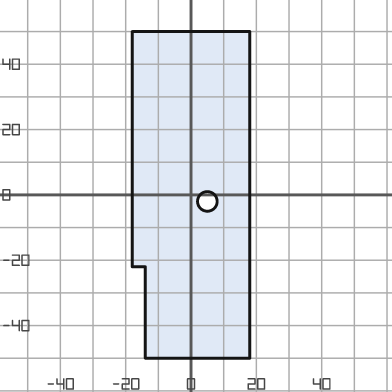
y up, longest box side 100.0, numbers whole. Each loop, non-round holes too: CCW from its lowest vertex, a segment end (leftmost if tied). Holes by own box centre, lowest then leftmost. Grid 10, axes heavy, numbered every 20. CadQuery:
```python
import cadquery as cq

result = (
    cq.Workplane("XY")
    .moveTo(-14.0, -50.0)
    .lineTo(18.0, -50.0)
    .lineTo(18.0, 50.0)
    .lineTo(-18.0, 50.0)
    .lineTo(-18.0, -22.0)
    .lineTo(-14.0, -22.0)
    .close()
    .moveTo(5.0, -2.0)
    .circle(3.0)
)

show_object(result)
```